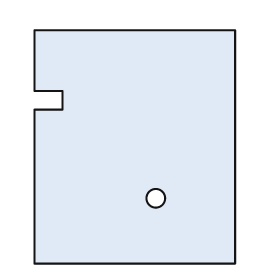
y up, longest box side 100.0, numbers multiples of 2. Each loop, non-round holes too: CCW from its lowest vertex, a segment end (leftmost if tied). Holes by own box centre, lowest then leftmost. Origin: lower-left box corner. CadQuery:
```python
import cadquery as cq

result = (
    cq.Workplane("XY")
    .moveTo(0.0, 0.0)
    .lineTo(86.0, 0.0)
    .lineTo(86.0, 100.0)
    .lineTo(0.0, 100.0)
    .lineTo(0.0, 74.0)
    .lineTo(12.0, 74.0)
    .lineTo(12.0, 66.0)
    .lineTo(0.0, 66.0)
    .close()
    .moveTo(52.0, 28.0)
    .circle(4.0)
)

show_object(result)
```